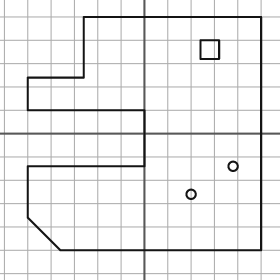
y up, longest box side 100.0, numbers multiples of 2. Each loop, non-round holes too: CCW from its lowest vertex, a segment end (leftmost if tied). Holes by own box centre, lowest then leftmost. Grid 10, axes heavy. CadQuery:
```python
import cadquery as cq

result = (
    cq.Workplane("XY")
    .moveTo(-36.0, -50.0)
    .lineTo(50.0, -50.0)
    .lineTo(50.0, 50.0)
    .lineTo(-26.0, 50.0)
    .lineTo(-26.0, 24.0)
    .lineTo(-50.0, 24.0)
    .lineTo(-50.0, 10.0)
    .lineTo(0.0, 10.0)
    .lineTo(0.0, -14.0)
    .lineTo(-50.0, -14.0)
    .lineTo(-50.0, -36.0)
    .close()
    .moveTo(20.0, -26.0)
    .circle(2.0)
    .moveTo(38.0, -14.0)
    .circle(2.0)
    .moveTo(24.0, 32.0)
    .lineTo(32.0, 32.0)
    .lineTo(32.0, 40.0)
    .lineTo(24.0, 40.0)
    .close()
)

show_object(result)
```